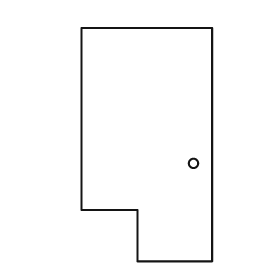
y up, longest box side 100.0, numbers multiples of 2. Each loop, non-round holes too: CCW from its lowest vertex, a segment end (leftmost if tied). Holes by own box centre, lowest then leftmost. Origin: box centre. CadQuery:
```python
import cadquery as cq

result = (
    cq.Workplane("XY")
    .moveTo(-4.0, -50.0)
    .lineTo(28.0, -50.0)
    .lineTo(28.0, 50.0)
    .lineTo(-28.0, 50.0)
    .lineTo(-28.0, -28.0)
    .lineTo(-4.0, -28.0)
    .close()
    .moveTo(20.0, -8.0)
    .circle(2.0)
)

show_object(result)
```